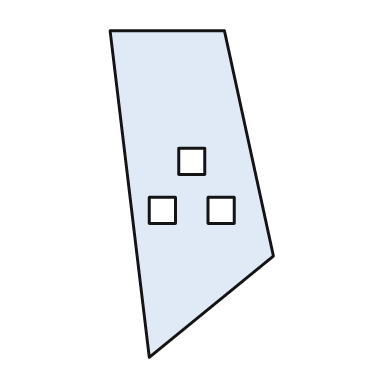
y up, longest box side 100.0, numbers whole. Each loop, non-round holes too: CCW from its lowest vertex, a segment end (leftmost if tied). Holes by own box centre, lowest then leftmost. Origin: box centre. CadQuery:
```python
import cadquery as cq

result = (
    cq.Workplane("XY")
    .moveTo(-13.0, -50.0)
    .lineTo(25.0, -19.0)
    .lineTo(10.0, 50.0)
    .lineTo(-25.0, 50.0)
    .close()
    .moveTo(-13.0, -9.0)
    .lineTo(-5.0, -9.0)
    .lineTo(-5.0, -1.0)
    .lineTo(-13.0, -1.0)
    .close()
    .moveTo(5.0, -9.0)
    .lineTo(13.0, -9.0)
    .lineTo(13.0, -1.0)
    .lineTo(5.0, -1.0)
    .close()
    .moveTo(-4.0, 6.0)
    .lineTo(4.0, 6.0)
    .lineTo(4.0, 14.0)
    .lineTo(-4.0, 14.0)
    .close()
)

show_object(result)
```